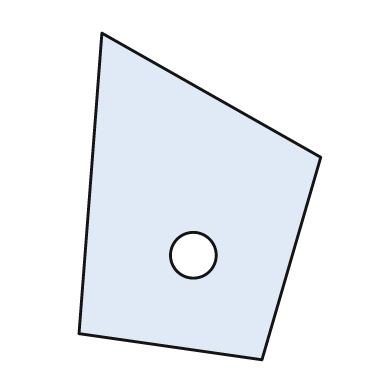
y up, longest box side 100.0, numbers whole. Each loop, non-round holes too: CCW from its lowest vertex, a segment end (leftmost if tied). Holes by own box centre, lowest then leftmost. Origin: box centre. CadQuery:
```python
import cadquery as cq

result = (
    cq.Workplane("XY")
    .moveTo(19.0, -50.0)
    .lineTo(37.0, 12.0)
    .lineTo(-30.0, 50.0)
    .lineTo(-37.0, -42.0)
    .close()
    .moveTo(-2.0, -18.0)
    .circle(7.0)
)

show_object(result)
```